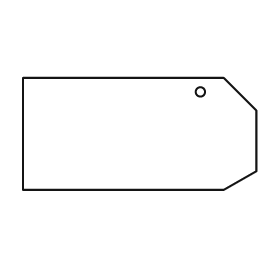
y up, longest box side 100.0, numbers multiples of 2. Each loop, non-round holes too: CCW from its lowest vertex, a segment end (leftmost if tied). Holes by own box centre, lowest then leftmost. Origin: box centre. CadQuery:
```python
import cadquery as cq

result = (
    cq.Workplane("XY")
    .moveTo(-50.0, -24.0)
    .lineTo(36.0, -24.0)
    .lineTo(50.0, -16.0)
    .lineTo(50.0, 10.0)
    .lineTo(36.0, 24.0)
    .lineTo(-50.0, 24.0)
    .close()
    .moveTo(26.0, 18.0)
    .circle(2.0)
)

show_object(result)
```